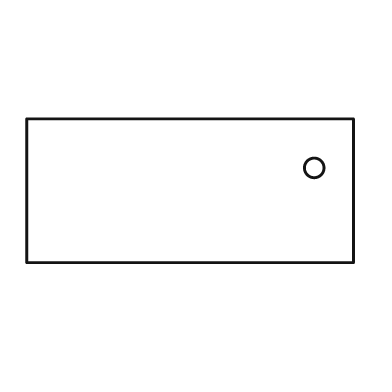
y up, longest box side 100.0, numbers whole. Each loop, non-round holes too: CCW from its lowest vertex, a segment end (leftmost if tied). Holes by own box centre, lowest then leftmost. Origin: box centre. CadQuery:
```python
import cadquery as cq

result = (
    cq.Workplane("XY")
    .moveTo(-50.0, -22.0)
    .lineTo(50.0, -22.0)
    .lineTo(50.0, 22.0)
    .lineTo(-50.0, 22.0)
    .close()
    .moveTo(38.0, 7.0)
    .circle(3.0)
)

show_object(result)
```